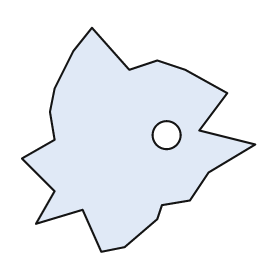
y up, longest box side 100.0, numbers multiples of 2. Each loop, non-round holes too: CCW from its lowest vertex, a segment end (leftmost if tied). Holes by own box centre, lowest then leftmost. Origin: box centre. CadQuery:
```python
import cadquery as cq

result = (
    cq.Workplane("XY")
    .moveTo(-16.0, -48.0)
    .lineTo(-6.0, -46.0)
    .lineTo(8.0, -34.0)
    .lineTo(10.0, -28.0)
    .lineTo(22.0, -26.0)
    .lineTo(30.0, -14.0)
    .lineTo(50.0, -2.0)
    .lineTo(26.0, 4.0)
    .lineTo(38.0, 20.0)
    .lineTo(20.0, 30.0)
    .lineTo(8.0, 34.0)
    .lineTo(-4.0, 30.0)
    .lineTo(-20.0, 48.0)
    .lineTo(-28.0, 38.0)
    .lineTo(-36.0, 22.0)
    .lineTo(-38.0, 12.0)
    .lineTo(-36.0, 0.0)
    .lineTo(-50.0, -8.0)
    .lineTo(-36.0, -22.0)
    .lineTo(-44.0, -36.0)
    .lineTo(-24.0, -30.0)
    .close()
    .moveTo(12.0, 2.0)
    .circle(6.0)
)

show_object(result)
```